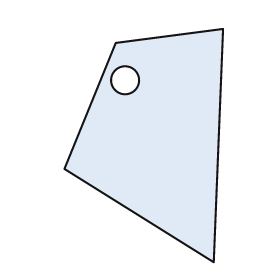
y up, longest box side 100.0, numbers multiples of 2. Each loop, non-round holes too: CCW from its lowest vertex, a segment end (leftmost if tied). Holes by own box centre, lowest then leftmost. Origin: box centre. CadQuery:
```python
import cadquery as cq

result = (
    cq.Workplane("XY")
    .moveTo(30.0, -50.0)
    .lineTo(34.0, 50.0)
    .lineTo(-12.0, 44.0)
    .lineTo(-34.0, -10.0)
    .close()
    .moveTo(-8.0, 28.0)
    .circle(6.0)
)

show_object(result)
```